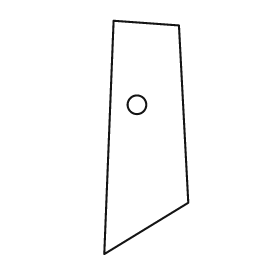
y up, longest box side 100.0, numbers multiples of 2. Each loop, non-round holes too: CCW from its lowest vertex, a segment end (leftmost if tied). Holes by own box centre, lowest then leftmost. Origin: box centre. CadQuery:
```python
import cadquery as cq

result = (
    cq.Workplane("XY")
    .moveTo(-18.0, -50.0)
    .lineTo(18.0, -28.0)
    .lineTo(14.0, 48.0)
    .lineTo(-14.0, 50.0)
    .close()
    .moveTo(-4.0, 14.0)
    .circle(4.0)
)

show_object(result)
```